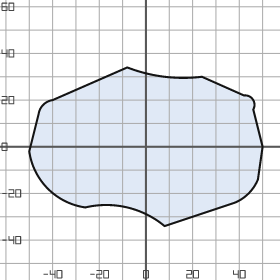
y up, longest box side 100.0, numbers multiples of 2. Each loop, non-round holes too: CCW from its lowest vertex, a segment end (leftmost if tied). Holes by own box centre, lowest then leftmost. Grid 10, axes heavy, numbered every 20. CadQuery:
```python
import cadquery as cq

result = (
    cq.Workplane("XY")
    .moveTo(8.0, -34.0)
    .lineTo(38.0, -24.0)
    .threePointArc((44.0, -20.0), (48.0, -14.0))
    .lineTo(50.0, 0.0)
    .lineTo(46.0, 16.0)
    .threePointArc((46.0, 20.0), (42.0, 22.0))
    .lineTo(24.0, 30.0)
    .threePointArc((8.0, 30.0), (-8.0, 34.0))
    .lineTo(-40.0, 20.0)
    .threePointArc((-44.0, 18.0), (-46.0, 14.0))
    .lineTo(-50.0, -2.0)
    .threePointArc((-42.0, -18.0), (-26.0, -26.0))
    .threePointArc((-8.0, -26.0), (8.0, -34.0))
    .close()
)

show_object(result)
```